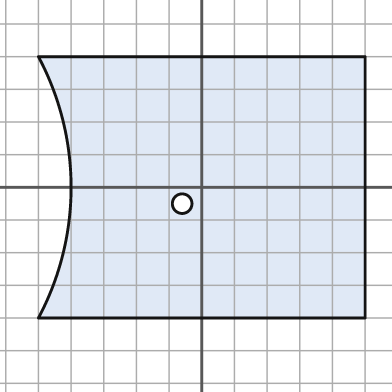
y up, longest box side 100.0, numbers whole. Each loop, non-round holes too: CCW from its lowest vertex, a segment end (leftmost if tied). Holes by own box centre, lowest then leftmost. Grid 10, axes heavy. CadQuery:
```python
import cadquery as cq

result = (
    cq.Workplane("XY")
    .moveTo(-50.0, -40.0)
    .lineTo(50.0, -40.0)
    .lineTo(50.0, 40.0)
    .lineTo(-50.0, 40.0)
    .threePointArc((-40.0, 0.0), (-50.0, -40.0))
    .close()
    .moveTo(-6.0, -5.0)
    .circle(3.0)
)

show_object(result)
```